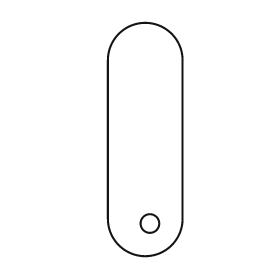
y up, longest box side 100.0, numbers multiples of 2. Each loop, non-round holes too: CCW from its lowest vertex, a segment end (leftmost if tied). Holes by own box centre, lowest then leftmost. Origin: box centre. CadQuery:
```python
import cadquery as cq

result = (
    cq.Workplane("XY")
    .moveTo(-16.0, -34.0)
    .threePointArc((0.0, -50.0), (16.0, -34.0))
    .lineTo(16.0, 34.0)
    .threePointArc((0.0, 50.0), (-16.0, 34.0))
    .close()
    .moveTo(2.0, -36.0)
    .circle(4.0)
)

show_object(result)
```